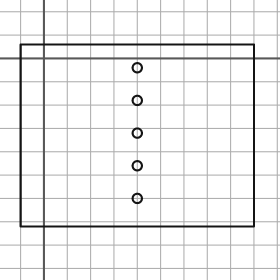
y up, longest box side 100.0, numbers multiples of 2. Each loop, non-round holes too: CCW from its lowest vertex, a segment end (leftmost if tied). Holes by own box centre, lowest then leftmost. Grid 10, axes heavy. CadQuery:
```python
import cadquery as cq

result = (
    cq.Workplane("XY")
    .moveTo(-10.0, -72.0)
    .lineTo(90.0, -72.0)
    .lineTo(90.0, 6.0)
    .lineTo(-10.0, 6.0)
    .close()
    .moveTo(40.0, -60.0)
    .circle(2.0)
    .moveTo(40.0, -46.0)
    .circle(2.0)
    .moveTo(40.0, -32.0)
    .circle(2.0)
    .moveTo(40.0, -18.0)
    .circle(2.0)
    .moveTo(40.0, -4.0)
    .circle(2.0)
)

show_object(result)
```